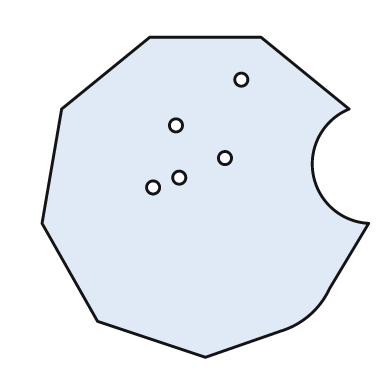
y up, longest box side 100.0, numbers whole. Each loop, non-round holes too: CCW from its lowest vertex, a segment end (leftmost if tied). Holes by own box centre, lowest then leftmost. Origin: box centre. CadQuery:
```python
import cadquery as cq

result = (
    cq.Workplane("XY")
    .moveTo(0.0, -49.0)
    .lineTo(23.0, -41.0)
    .threePointArc((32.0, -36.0), (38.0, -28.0))
    .lineTo(50.0, -8.0)
    .threePointArc((33.0, 7.0), (44.0, 27.0))
    .lineTo(17.0, 49.0)
    .lineTo(-17.0, 49.0)
    .lineTo(-44.0, 27.0)
    .lineTo(-50.0, -8.0)
    .lineTo(-33.0, -38.0)
    .close()
    .moveTo(-16.0, 3.0)
    .circle(2.0)
    .moveTo(-8.0, 6.0)
    .circle(2.0)
    .moveTo(6.0, 12.0)
    .circle(2.0)
    .moveTo(-9.0, 22.0)
    .circle(2.0)
    .moveTo(11.0, 36.0)
    .circle(2.0)
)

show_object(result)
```